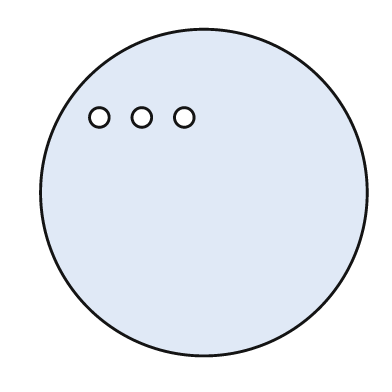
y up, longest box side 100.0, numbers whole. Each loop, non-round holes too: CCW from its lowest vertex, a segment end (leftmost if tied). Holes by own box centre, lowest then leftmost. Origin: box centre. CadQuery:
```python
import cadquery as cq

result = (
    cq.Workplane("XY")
    .moveTo(0.0, 0.0)
    .circle(50.0)
    .moveTo(-32.0, 23.0)
    .circle(3.0)
    .moveTo(-19.0, 23.0)
    .circle(3.0)
    .moveTo(-6.0, 23.0)
    .circle(3.0)
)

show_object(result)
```